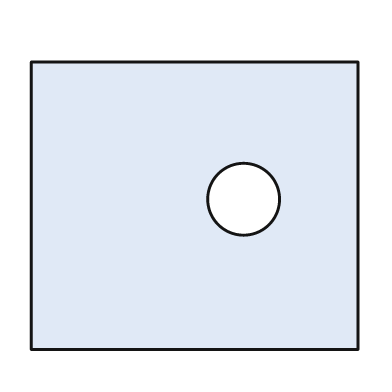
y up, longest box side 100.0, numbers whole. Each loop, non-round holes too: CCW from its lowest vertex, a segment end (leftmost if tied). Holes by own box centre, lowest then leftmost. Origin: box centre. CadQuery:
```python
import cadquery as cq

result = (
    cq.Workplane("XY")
    .moveTo(-50.0, -44.0)
    .lineTo(50.0, -44.0)
    .lineTo(50.0, 44.0)
    .lineTo(-50.0, 44.0)
    .close()
    .moveTo(15.0, 2.0)
    .circle(11.0)
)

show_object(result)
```